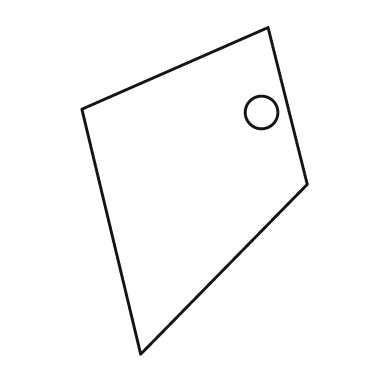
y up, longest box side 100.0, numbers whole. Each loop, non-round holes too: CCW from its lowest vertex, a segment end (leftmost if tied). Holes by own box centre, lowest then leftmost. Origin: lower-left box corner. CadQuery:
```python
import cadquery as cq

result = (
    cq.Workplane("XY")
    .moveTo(18.0, 0.0)
    .lineTo(69.0, 52.0)
    .lineTo(57.0, 100.0)
    .lineTo(0.0, 75.0)
    .close()
    .moveTo(55.0, 74.0)
    .circle(5.0)
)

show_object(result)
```